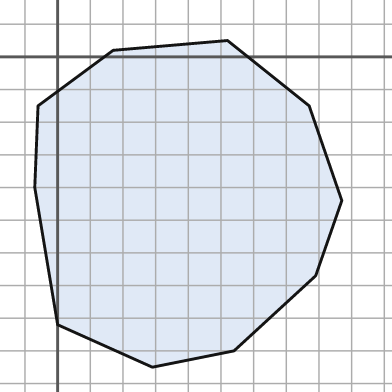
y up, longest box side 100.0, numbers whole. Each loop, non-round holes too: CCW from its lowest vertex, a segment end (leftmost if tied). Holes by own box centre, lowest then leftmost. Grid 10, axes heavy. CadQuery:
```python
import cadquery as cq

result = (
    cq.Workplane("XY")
    .moveTo(29.0, -95.0)
    .lineTo(54.0, -90.0)
    .lineTo(79.0, -67.0)
    .lineTo(87.0, -44.0)
    .lineTo(77.0, -15.0)
    .lineTo(52.0, 5.0)
    .lineTo(17.0, 2.0)
    .lineTo(-6.0, -15.0)
    .lineTo(-7.0, -40.0)
    .lineTo(0.0, -82.0)
    .close()
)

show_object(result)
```